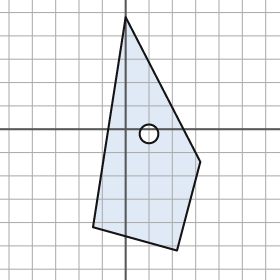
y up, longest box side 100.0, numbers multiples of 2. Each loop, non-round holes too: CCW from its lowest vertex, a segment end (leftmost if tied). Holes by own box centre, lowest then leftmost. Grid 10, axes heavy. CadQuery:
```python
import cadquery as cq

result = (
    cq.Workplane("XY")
    .moveTo(22.0, -52.0)
    .lineTo(32.0, -14.0)
    .lineTo(0.0, 48.0)
    .lineTo(-14.0, -42.0)
    .close()
    .moveTo(10.0, -2.0)
    .circle(4.0)
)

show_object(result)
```